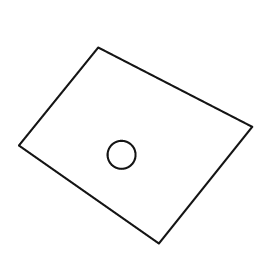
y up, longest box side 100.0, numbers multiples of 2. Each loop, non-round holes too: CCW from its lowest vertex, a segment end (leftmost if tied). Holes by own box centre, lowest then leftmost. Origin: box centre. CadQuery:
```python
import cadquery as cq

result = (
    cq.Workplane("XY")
    .moveTo(10.0, -42.0)
    .lineTo(50.0, 8.0)
    .lineTo(-16.0, 42.0)
    .lineTo(-50.0, 0.0)
    .close()
    .moveTo(-6.0, -4.0)
    .circle(6.0)
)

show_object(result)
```